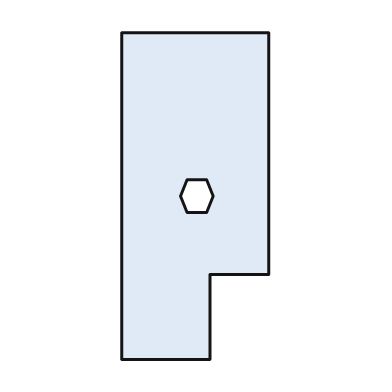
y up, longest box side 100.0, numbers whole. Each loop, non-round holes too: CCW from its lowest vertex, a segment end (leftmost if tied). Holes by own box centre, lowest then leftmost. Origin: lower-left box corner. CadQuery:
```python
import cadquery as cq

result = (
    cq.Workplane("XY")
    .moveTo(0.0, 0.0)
    .lineTo(27.0, 0.0)
    .lineTo(27.0, 26.0)
    .lineTo(45.0, 26.0)
    .lineTo(45.0, 100.0)
    .lineTo(0.0, 100.0)
    .close()
    .moveTo(20.0, 45.0)
    .lineTo(26.0, 45.0)
    .lineTo(28.0, 50.0)
    .lineTo(26.0, 55.0)
    .lineTo(20.0, 55.0)
    .lineTo(18.0, 50.0)
    .close()
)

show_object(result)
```